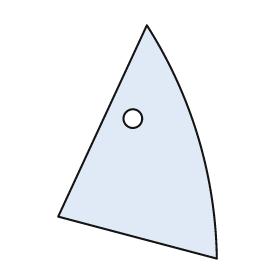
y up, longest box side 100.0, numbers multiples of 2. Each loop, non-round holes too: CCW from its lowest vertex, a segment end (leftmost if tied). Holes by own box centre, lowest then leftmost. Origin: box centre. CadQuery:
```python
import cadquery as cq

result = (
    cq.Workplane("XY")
    .moveTo(34.0, -50.0)
    .threePointArc((26.0, 2.0), (4.0, 50.0))
    .lineTo(-34.0, -32.0)
    .close()
    .moveTo(-2.0, 10.0)
    .circle(4.0)
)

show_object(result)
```